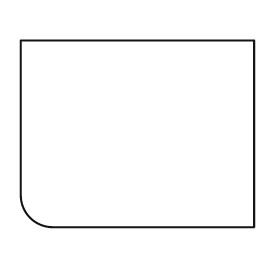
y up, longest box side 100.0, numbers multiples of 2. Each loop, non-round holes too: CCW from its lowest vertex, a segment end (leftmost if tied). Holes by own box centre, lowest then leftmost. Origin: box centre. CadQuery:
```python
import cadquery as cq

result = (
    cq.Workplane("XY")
    .moveTo(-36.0, -40.0)
    .lineTo(50.0, -40.0)
    .lineTo(50.0, 40.0)
    .lineTo(-50.0, 40.0)
    .lineTo(-50.0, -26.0)
    .threePointArc((-46.0, -36.0), (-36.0, -40.0))
    .close()
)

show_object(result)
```